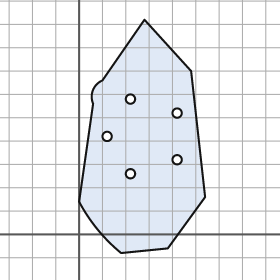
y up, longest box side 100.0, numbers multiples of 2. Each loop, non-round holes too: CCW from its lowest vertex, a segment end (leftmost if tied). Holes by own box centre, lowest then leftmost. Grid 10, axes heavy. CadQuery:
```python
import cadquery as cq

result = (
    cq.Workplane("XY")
    .moveTo(18.0, -8.0)
    .lineTo(38.0, -6.0)
    .lineTo(54.0, 16.0)
    .lineTo(48.0, 70.0)
    .lineTo(28.0, 92.0)
    .lineTo(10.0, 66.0)
    .threePointArc((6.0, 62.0), (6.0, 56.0))
    .lineTo(0.0, 14.0)
    .threePointArc((8.0, 2.0), (18.0, -8.0))
    .close()
    .moveTo(22.0, 26.0)
    .circle(2.0)
    .moveTo(42.0, 32.0)
    .circle(2.0)
    .moveTo(12.0, 42.0)
    .circle(2.0)
    .moveTo(42.0, 52.0)
    .circle(2.0)
    .moveTo(22.0, 58.0)
    .circle(2.0)
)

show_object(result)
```